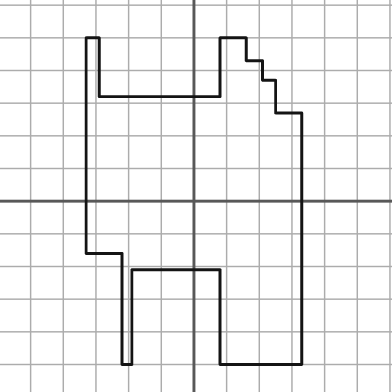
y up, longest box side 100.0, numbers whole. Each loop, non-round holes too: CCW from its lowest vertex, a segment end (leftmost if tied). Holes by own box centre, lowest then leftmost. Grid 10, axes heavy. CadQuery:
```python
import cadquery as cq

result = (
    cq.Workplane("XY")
    .moveTo(-22.0, -50.0)
    .lineTo(-19.0, -50.0)
    .lineTo(-19.0, -21.0)
    .lineTo(8.0, -21.0)
    .lineTo(8.0, -50.0)
    .lineTo(33.0, -50.0)
    .lineTo(33.0, 27.0)
    .lineTo(25.0, 27.0)
    .lineTo(25.0, 37.0)
    .lineTo(21.0, 37.0)
    .lineTo(21.0, 43.0)
    .lineTo(16.0, 43.0)
    .lineTo(16.0, 50.0)
    .lineTo(8.0, 50.0)
    .lineTo(8.0, 32.0)
    .lineTo(-29.0, 32.0)
    .lineTo(-29.0, 50.0)
    .lineTo(-33.0, 50.0)
    .lineTo(-33.0, -16.0)
    .lineTo(-22.0, -16.0)
    .close()
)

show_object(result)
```